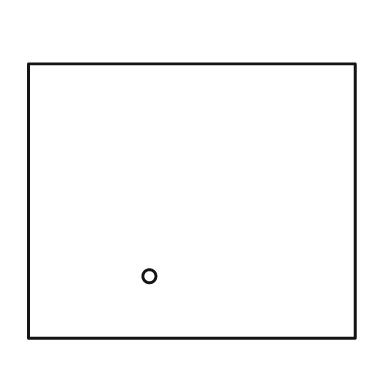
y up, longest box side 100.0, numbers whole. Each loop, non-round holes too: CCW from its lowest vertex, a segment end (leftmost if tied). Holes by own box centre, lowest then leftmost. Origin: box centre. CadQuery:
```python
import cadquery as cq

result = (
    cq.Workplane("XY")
    .moveTo(-50.0, -42.0)
    .lineTo(50.0, -42.0)
    .lineTo(50.0, 42.0)
    .lineTo(-50.0, 42.0)
    .close()
    .moveTo(-13.0, -23.0)
    .circle(2.0)
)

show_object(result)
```